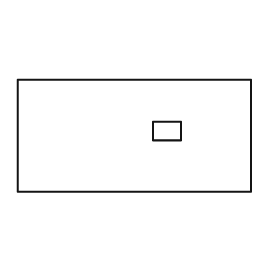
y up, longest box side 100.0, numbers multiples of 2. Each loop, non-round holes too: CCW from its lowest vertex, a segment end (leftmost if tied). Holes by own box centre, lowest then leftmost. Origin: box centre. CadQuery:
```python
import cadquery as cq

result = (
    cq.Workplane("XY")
    .moveTo(-50.0, -24.0)
    .lineTo(50.0, -24.0)
    .lineTo(50.0, 24.0)
    .lineTo(-50.0, 24.0)
    .close()
    .moveTo(8.0, -2.0)
    .lineTo(20.0, -2.0)
    .lineTo(20.0, 6.0)
    .lineTo(8.0, 6.0)
    .close()
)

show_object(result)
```